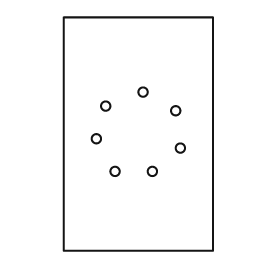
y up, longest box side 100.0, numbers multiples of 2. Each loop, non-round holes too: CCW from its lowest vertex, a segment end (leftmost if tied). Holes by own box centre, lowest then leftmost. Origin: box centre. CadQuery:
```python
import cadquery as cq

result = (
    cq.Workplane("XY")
    .moveTo(-32.0, -50.0)
    .lineTo(32.0, -50.0)
    .lineTo(32.0, 50.0)
    .lineTo(-32.0, 50.0)
    .close()
    .moveTo(-10.0, -16.0)
    .circle(2.0)
    .moveTo(6.0, -16.0)
    .circle(2.0)
    .moveTo(18.0, -6.0)
    .circle(2.0)
    .moveTo(-18.0, -2.0)
    .circle(2.0)
    .moveTo(16.0, 10.0)
    .circle(2.0)
    .moveTo(-14.0, 12.0)
    .circle(2.0)
    .moveTo(2.0, 18.0)
    .circle(2.0)
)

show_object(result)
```